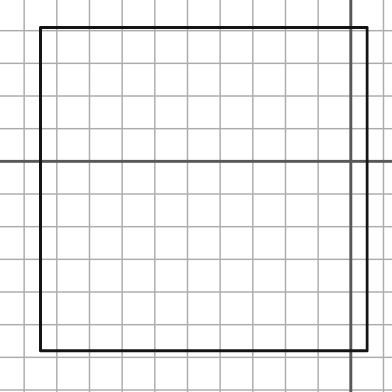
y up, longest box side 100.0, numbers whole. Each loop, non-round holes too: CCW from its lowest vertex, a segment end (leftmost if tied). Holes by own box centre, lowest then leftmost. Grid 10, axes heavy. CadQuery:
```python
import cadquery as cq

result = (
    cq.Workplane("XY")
    .moveTo(-95.0, -58.0)
    .lineTo(5.0, -58.0)
    .lineTo(5.0, 41.0)
    .lineTo(-95.0, 41.0)
    .close()
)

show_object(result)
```